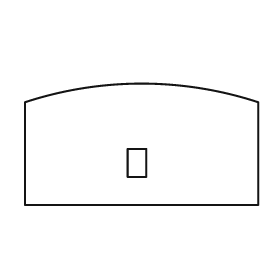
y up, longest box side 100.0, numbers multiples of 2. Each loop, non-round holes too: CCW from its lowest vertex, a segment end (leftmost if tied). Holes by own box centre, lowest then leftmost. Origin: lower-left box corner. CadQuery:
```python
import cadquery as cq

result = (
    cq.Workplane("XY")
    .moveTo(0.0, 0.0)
    .lineTo(100.0, 0.0)
    .lineTo(100.0, 44.0)
    .threePointArc((50.0, 52.0), (0.0, 44.0))
    .close()
    .moveTo(44.0, 12.0)
    .lineTo(52.0, 12.0)
    .lineTo(52.0, 24.0)
    .lineTo(44.0, 24.0)
    .close()
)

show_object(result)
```